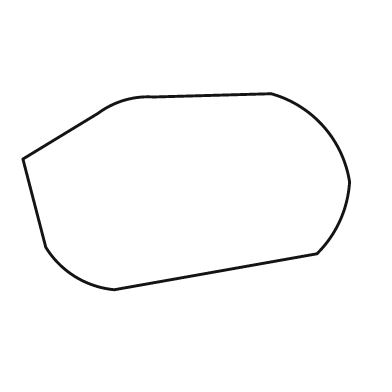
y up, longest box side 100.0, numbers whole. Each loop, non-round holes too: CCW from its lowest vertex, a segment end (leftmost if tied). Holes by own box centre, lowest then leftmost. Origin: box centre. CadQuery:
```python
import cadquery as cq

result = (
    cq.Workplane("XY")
    .moveTo(-22.0, -30.0)
    .lineTo(40.0, -19.0)
    .threePointArc((47.0, -9.0), (50.0, 3.0))
    .threePointArc((42.0, 20.0), (26.0, 30.0))
    .lineTo(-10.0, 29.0)
    .threePointArc((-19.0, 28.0), (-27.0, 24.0))
    .lineTo(-50.0, 10.0)
    .lineTo(-43.0, -17.0)
    .threePointArc((-34.0, -26.0), (-22.0, -30.0))
    .close()
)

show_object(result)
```